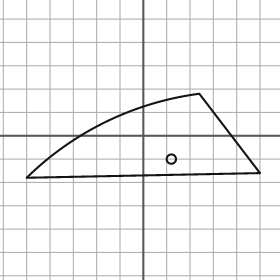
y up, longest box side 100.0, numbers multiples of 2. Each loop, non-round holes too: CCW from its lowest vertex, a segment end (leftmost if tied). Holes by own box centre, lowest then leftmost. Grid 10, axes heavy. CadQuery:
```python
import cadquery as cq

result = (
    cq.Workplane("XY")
    .moveTo(-50.0, -18.0)
    .lineTo(50.0, -16.0)
    .lineTo(24.0, 18.0)
    .threePointArc((-16.0, 6.0), (-50.0, -18.0))
    .close()
    .moveTo(12.0, -10.0)
    .circle(2.0)
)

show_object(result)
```